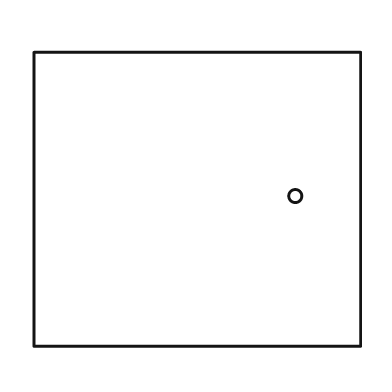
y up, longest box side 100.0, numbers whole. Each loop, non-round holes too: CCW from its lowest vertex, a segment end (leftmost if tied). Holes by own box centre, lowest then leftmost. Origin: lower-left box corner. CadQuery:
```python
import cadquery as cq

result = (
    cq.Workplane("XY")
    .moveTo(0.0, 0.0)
    .lineTo(100.0, 0.0)
    .lineTo(100.0, 90.0)
    .lineTo(0.0, 90.0)
    .close()
    .moveTo(80.0, 46.0)
    .circle(2.0)
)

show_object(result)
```